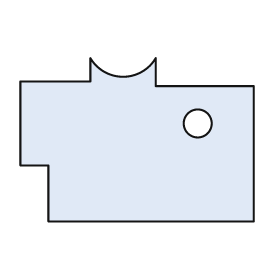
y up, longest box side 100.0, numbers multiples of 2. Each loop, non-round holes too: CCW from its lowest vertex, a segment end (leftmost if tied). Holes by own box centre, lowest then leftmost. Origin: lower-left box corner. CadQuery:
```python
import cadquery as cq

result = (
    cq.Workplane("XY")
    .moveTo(12.0, 0.0)
    .lineTo(100.0, 0.0)
    .lineTo(100.0, 58.0)
    .lineTo(58.0, 58.0)
    .lineTo(58.0, 70.0)
    .threePointArc((44.0, 62.0), (30.0, 70.0))
    .lineTo(30.0, 60.0)
    .lineTo(0.0, 60.0)
    .lineTo(0.0, 24.0)
    .lineTo(12.0, 24.0)
    .close()
    .moveTo(76.0, 42.0)
    .circle(6.0)
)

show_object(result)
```